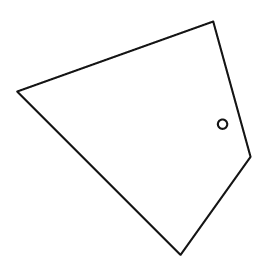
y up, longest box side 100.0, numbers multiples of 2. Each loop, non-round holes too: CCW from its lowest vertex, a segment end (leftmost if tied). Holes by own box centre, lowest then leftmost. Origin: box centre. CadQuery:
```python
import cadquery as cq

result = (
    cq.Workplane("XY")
    .moveTo(20.0, -50.0)
    .lineTo(50.0, -8.0)
    .lineTo(34.0, 50.0)
    .lineTo(-50.0, 20.0)
    .close()
    .moveTo(38.0, 6.0)
    .circle(2.0)
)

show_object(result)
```